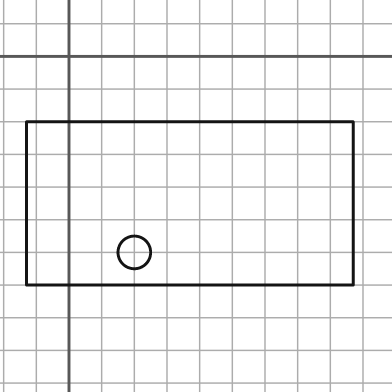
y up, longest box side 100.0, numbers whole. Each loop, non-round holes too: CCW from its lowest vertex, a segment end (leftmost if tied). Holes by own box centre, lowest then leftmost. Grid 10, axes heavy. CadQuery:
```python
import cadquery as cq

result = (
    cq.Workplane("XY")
    .moveTo(-13.0, -70.0)
    .lineTo(87.0, -70.0)
    .lineTo(87.0, -20.0)
    .lineTo(-13.0, -20.0)
    .close()
    .moveTo(20.0, -60.0)
    .circle(5.0)
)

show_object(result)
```